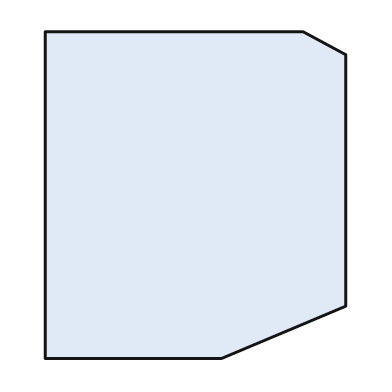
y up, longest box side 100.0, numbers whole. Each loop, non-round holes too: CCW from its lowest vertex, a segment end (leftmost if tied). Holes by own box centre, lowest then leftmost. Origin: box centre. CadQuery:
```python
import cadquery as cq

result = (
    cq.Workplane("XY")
    .moveTo(-46.0, -50.0)
    .lineTo(8.0, -50.0)
    .lineTo(46.0, -34.0)
    .lineTo(46.0, 43.0)
    .lineTo(33.0, 50.0)
    .lineTo(-46.0, 50.0)
    .close()
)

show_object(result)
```